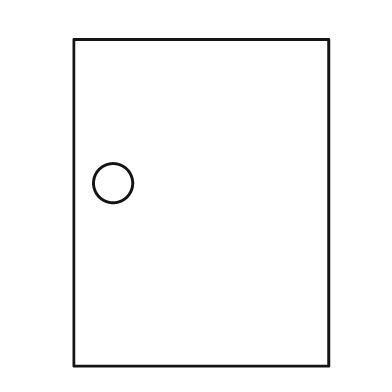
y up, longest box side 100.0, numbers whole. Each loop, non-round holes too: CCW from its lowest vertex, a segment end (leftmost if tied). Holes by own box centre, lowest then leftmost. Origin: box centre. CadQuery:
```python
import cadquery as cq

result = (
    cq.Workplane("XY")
    .moveTo(-39.0, -50.0)
    .lineTo(39.0, -50.0)
    .lineTo(39.0, 50.0)
    .lineTo(-39.0, 50.0)
    .close()
    .moveTo(-27.0, 6.0)
    .circle(6.0)
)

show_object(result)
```